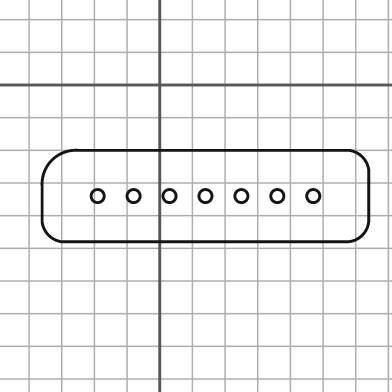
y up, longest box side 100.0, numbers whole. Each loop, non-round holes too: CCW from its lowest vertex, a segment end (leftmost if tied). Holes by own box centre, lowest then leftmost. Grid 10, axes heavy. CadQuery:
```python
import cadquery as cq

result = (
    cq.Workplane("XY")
    .moveTo(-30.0, -48.0)
    .lineTo(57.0, -48.0)
    .threePointArc((62.0, -46.0), (64.0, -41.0))
    .lineTo(64.0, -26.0)
    .threePointArc((62.0, -22.0), (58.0, -20.0))
    .lineTo(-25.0, -20.0)
    .threePointArc((-33.0, -23.0), (-36.0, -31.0))
    .lineTo(-36.0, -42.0)
    .threePointArc((-34.0, -46.0), (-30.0, -48.0))
    .close()
    .moveTo(-19.0, -34.0)
    .circle(2.0)
    .moveTo(-8.0, -34.0)
    .circle(2.0)
    .moveTo(3.0, -34.0)
    .circle(2.0)
    .moveTo(14.0, -34.0)
    .circle(2.0)
    .moveTo(25.0, -34.0)
    .circle(2.0)
    .moveTo(36.0, -34.0)
    .circle(2.0)
    .moveTo(47.0, -34.0)
    .circle(2.0)
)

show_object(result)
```